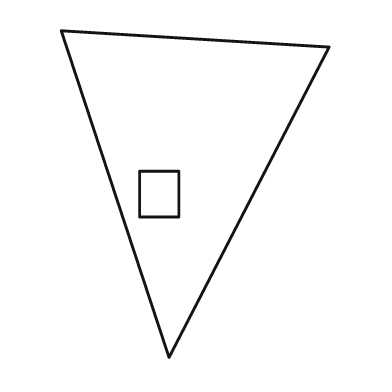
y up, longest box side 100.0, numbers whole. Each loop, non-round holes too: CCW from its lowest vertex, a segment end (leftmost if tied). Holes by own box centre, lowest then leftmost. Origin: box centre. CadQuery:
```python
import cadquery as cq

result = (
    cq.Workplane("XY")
    .moveTo(-8.0, -50.0)
    .lineTo(41.0, 45.0)
    .lineTo(-41.0, 50.0)
    .close()
    .moveTo(-17.0, -7.0)
    .lineTo(-5.0, -7.0)
    .lineTo(-5.0, 7.0)
    .lineTo(-17.0, 7.0)
    .close()
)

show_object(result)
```